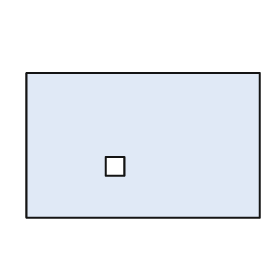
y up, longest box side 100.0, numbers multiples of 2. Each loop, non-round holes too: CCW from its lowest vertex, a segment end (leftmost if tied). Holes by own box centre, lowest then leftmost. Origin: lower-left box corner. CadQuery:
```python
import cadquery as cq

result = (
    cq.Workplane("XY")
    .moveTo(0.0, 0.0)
    .lineTo(100.0, 0.0)
    .lineTo(100.0, 62.0)
    .lineTo(0.0, 62.0)
    .close()
    .moveTo(34.0, 18.0)
    .lineTo(42.0, 18.0)
    .lineTo(42.0, 26.0)
    .lineTo(34.0, 26.0)
    .close()
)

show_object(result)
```